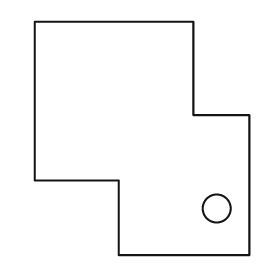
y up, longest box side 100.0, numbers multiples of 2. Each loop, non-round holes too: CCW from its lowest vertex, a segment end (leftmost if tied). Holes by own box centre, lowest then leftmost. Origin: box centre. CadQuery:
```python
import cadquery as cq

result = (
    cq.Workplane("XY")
    .moveTo(-10.0, -50.0)
    .lineTo(46.0, -50.0)
    .lineTo(46.0, 10.0)
    .lineTo(22.0, 10.0)
    .lineTo(22.0, 50.0)
    .lineTo(-46.0, 50.0)
    .lineTo(-46.0, -18.0)
    .lineTo(-10.0, -18.0)
    .close()
    .moveTo(32.0, -30.0)
    .circle(6.0)
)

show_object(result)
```